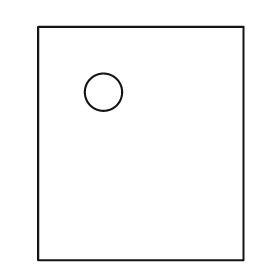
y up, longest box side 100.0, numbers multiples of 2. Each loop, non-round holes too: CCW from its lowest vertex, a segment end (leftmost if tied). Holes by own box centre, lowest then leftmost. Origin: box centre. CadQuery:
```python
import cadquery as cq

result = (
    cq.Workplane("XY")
    .moveTo(-44.0, -50.0)
    .lineTo(44.0, -50.0)
    .lineTo(44.0, 50.0)
    .lineTo(-44.0, 50.0)
    .close()
    .moveTo(-16.0, 22.0)
    .circle(8.0)
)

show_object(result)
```